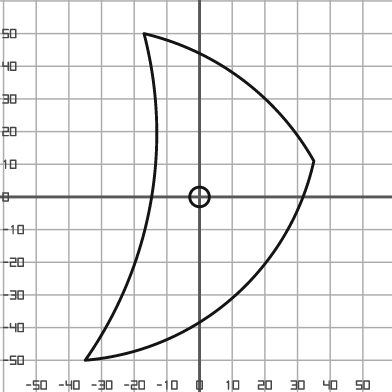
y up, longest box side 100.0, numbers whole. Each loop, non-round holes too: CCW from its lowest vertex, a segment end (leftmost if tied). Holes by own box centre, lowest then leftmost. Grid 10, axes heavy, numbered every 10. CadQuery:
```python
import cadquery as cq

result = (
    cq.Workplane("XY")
    .moveTo(-35.0, -50.0)
    .threePointArc((10.0, -31.0), (35.0, 11.0))
    .threePointArc((13.0, 36.0), (-17.0, 50.0))
    .threePointArc((-15.0, -2.0), (-35.0, -50.0))
    .close()
    .moveTo(0.0, 0.0)
    .circle(3.0)
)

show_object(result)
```